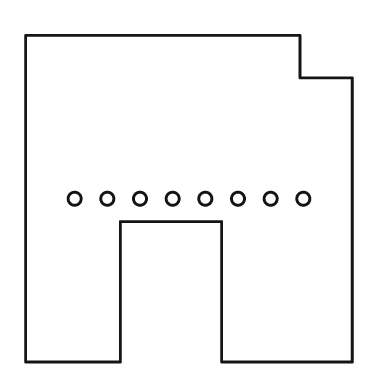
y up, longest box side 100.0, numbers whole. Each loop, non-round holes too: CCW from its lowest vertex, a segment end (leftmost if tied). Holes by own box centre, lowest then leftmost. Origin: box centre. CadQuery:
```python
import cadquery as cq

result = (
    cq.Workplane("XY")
    .moveTo(-50.0, -50.0)
    .lineTo(-21.0, -50.0)
    .lineTo(-21.0, -7.0)
    .lineTo(10.0, -7.0)
    .lineTo(10.0, -50.0)
    .lineTo(50.0, -50.0)
    .lineTo(50.0, 37.0)
    .lineTo(34.0, 37.0)
    .lineTo(34.0, 50.0)
    .lineTo(-50.0, 50.0)
    .close()
    .moveTo(-35.0, 0.0)
    .circle(2.0)
    .moveTo(-25.0, 0.0)
    .circle(2.0)
    .moveTo(-15.0, 0.0)
    .circle(2.0)
    .moveTo(-5.0, 0.0)
    .circle(2.0)
    .moveTo(5.0, 0.0)
    .circle(2.0)
    .moveTo(15.0, 0.0)
    .circle(2.0)
    .moveTo(25.0, 0.0)
    .circle(2.0)
    .moveTo(35.0, 0.0)
    .circle(2.0)
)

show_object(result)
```